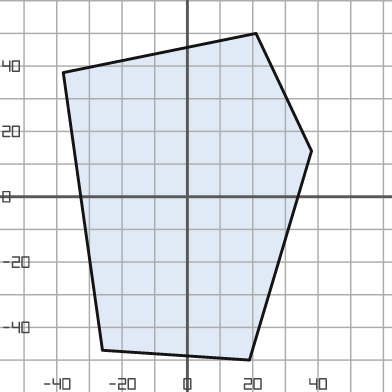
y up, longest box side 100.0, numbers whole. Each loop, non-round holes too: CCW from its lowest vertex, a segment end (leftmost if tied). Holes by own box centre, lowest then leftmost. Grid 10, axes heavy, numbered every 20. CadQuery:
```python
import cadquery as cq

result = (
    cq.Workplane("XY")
    .moveTo(19.0, -50.0)
    .lineTo(38.0, 14.0)
    .lineTo(21.0, 50.0)
    .lineTo(-38.0, 38.0)
    .lineTo(-26.0, -47.0)
    .close()
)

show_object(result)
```